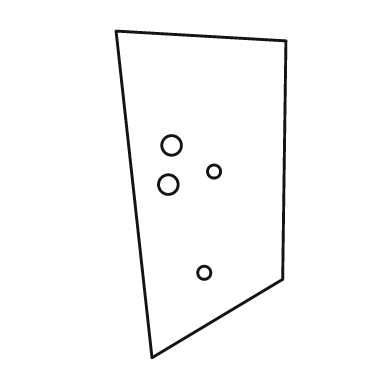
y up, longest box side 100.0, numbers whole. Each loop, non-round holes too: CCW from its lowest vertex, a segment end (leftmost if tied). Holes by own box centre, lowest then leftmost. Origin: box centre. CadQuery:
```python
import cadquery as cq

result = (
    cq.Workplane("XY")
    .moveTo(-15.0, -50.0)
    .lineTo(25.0, -26.0)
    .lineTo(26.0, 47.0)
    .lineTo(-26.0, 50.0)
    .close()
    .moveTo(1.0, -24.0)
    .circle(2.0)
    .moveTo(-10.0, 3.0)
    .circle(3.0)
    .moveTo(4.0, 7.0)
    .circle(2.0)
    .moveTo(-9.0, 15.0)
    .circle(3.0)
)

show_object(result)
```